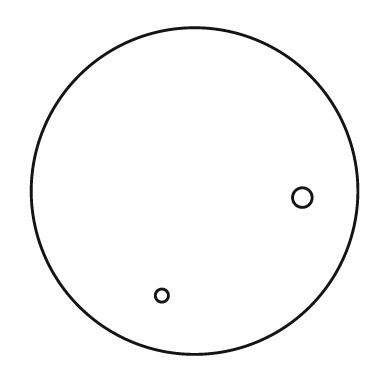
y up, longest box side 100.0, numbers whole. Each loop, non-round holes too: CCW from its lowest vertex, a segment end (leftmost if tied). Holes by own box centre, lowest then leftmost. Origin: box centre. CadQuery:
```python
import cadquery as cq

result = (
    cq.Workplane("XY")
    .moveTo(0.0, 0.0)
    .circle(50.0)
    .moveTo(-10.0, -32.0)
    .circle(2.0)
    .moveTo(33.0, -2.0)
    .circle(3.0)
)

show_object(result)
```